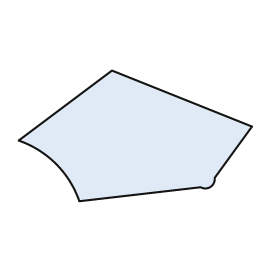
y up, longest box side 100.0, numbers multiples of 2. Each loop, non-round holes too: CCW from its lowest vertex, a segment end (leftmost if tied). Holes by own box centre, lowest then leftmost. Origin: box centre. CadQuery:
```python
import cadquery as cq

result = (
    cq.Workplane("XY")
    .moveTo(-24.0, -28.0)
    .lineTo(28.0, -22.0)
    .threePointArc((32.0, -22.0), (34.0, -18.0))
    .lineTo(50.0, 4.0)
    .lineTo(-10.0, 28.0)
    .lineTo(-50.0, -2.0)
    .threePointArc((-34.0, -12.0), (-24.0, -28.0))
    .close()
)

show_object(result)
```